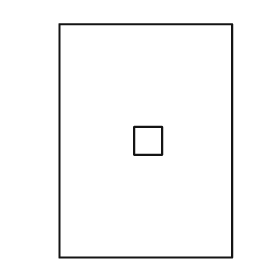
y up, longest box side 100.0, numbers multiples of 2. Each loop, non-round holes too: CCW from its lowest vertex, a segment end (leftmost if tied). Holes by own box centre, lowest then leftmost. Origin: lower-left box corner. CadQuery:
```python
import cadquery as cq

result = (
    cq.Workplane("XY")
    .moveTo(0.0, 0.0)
    .lineTo(74.0, 0.0)
    .lineTo(74.0, 100.0)
    .lineTo(0.0, 100.0)
    .close()
    .moveTo(32.0, 44.0)
    .lineTo(44.0, 44.0)
    .lineTo(44.0, 56.0)
    .lineTo(32.0, 56.0)
    .close()
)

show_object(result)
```